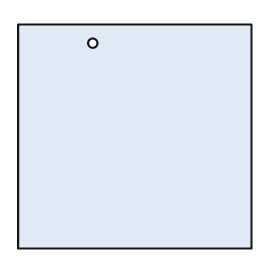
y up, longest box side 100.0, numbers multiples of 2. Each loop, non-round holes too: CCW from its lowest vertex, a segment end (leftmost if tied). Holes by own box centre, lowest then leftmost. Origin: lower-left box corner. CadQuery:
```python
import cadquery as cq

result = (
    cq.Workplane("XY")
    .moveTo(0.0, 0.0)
    .lineTo(100.0, 0.0)
    .lineTo(100.0, 96.0)
    .lineTo(0.0, 96.0)
    .close()
    .moveTo(32.0, 88.0)
    .circle(2.0)
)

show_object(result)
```